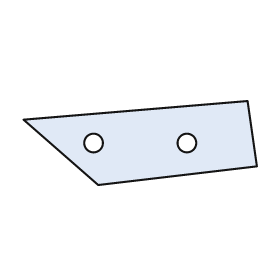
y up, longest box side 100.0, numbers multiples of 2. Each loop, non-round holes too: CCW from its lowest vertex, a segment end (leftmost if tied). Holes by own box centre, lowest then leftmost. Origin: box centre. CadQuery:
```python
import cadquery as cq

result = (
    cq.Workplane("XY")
    .moveTo(-18.0, -18.0)
    .lineTo(50.0, -10.0)
    .lineTo(46.0, 18.0)
    .lineTo(-50.0, 10.0)
    .close()
    .moveTo(-20.0, 0.0)
    .circle(4.0)
    .moveTo(20.0, 0.0)
    .circle(4.0)
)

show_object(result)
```